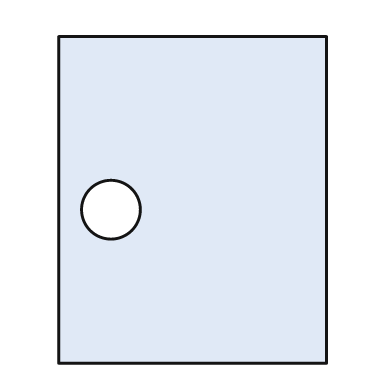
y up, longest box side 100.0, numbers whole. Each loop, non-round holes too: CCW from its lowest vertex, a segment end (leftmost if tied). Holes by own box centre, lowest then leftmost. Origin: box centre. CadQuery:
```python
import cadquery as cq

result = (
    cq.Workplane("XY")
    .moveTo(-41.0, -50.0)
    .lineTo(41.0, -50.0)
    .lineTo(41.0, 50.0)
    .lineTo(-41.0, 50.0)
    .close()
    .moveTo(-25.0, -3.0)
    .circle(9.0)
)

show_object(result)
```